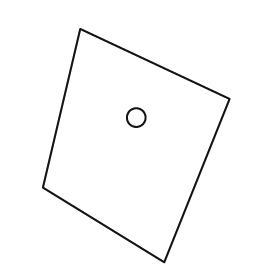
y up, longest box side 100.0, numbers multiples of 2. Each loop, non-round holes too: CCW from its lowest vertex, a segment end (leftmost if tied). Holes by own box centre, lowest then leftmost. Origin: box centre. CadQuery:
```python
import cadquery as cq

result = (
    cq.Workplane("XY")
    .moveTo(12.0, -50.0)
    .lineTo(40.0, 20.0)
    .lineTo(-24.0, 50.0)
    .lineTo(-40.0, -18.0)
    .close()
    .moveTo(0.0, 12.0)
    .circle(4.0)
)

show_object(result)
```